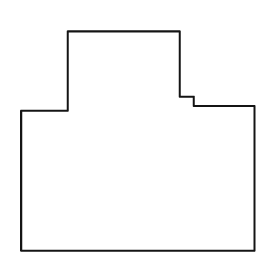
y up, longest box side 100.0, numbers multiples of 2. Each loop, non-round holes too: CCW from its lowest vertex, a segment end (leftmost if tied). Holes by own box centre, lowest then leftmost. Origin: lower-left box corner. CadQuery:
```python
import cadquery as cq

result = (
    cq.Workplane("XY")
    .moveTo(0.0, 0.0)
    .lineTo(100.0, 0.0)
    .lineTo(100.0, 62.0)
    .lineTo(74.0, 62.0)
    .lineTo(74.0, 66.0)
    .lineTo(68.0, 66.0)
    .lineTo(68.0, 94.0)
    .lineTo(20.0, 94.0)
    .lineTo(20.0, 60.0)
    .lineTo(0.0, 60.0)
    .close()
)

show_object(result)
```